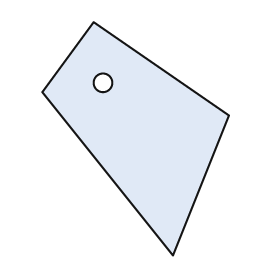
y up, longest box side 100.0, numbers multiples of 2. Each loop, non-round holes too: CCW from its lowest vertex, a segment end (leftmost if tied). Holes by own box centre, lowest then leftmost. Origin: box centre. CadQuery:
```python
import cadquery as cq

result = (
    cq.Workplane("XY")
    .moveTo(16.0, -50.0)
    .lineTo(40.0, 10.0)
    .lineTo(-18.0, 50.0)
    .lineTo(-40.0, 20.0)
    .close()
    .moveTo(-14.0, 24.0)
    .circle(4.0)
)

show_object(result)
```